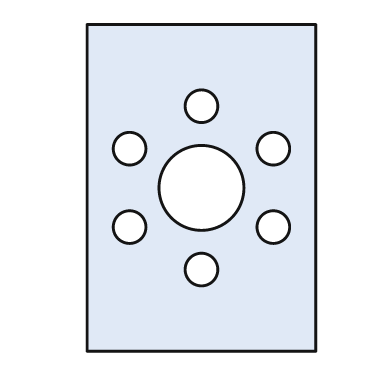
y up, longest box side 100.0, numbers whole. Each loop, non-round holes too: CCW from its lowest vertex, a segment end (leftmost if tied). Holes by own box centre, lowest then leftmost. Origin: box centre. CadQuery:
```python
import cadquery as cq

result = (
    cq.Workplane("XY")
    .moveTo(-35.0, -50.0)
    .lineTo(35.0, -50.0)
    .lineTo(35.0, 50.0)
    .lineTo(-35.0, 50.0)
    .close()
    .moveTo(0.0, -25.0)
    .circle(5.0)
    .moveTo(-22.0, -12.0)
    .circle(5.0)
    .moveTo(22.0, -12.0)
    .circle(5.0)
    .moveTo(0.0, 0.0)
    .circle(13.0)
    .moveTo(-22.0, 12.0)
    .circle(5.0)
    .moveTo(22.0, 12.0)
    .circle(5.0)
    .moveTo(0.0, 25.0)
    .circle(5.0)
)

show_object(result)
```